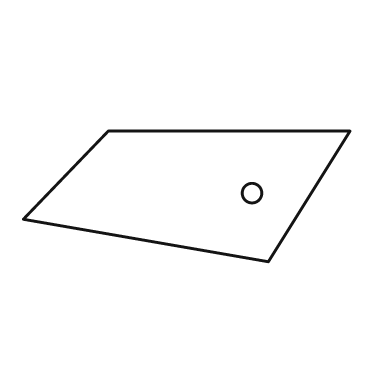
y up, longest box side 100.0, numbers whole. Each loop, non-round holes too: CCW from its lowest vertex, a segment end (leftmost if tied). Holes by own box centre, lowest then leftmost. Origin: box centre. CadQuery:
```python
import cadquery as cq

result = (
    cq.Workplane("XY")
    .moveTo(25.0, -20.0)
    .lineTo(50.0, 20.0)
    .lineTo(-24.0, 20.0)
    .lineTo(-50.0, -7.0)
    .close()
    .moveTo(20.0, 1.0)
    .circle(3.0)
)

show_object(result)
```